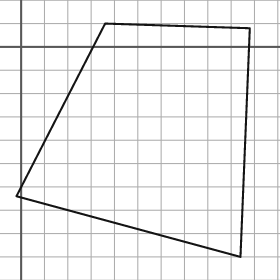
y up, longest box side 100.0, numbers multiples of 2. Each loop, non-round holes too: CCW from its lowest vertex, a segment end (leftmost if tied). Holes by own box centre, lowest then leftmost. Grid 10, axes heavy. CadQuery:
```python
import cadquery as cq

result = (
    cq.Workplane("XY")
    .moveTo(94.0, -90.0)
    .lineTo(98.0, 8.0)
    .lineTo(36.0, 10.0)
    .lineTo(-2.0, -64.0)
    .close()
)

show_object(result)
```